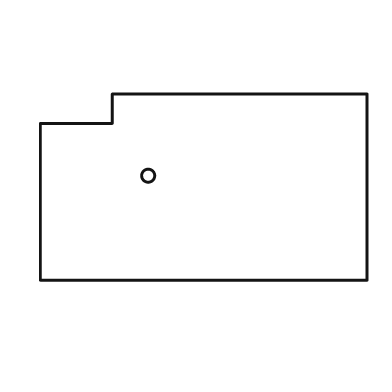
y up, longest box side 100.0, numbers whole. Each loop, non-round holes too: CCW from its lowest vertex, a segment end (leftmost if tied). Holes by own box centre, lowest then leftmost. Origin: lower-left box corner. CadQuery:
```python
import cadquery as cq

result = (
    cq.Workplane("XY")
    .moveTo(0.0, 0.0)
    .lineTo(100.0, 0.0)
    .lineTo(100.0, 57.0)
    .lineTo(22.0, 57.0)
    .lineTo(22.0, 48.0)
    .lineTo(0.0, 48.0)
    .close()
    .moveTo(33.0, 32.0)
    .circle(2.0)
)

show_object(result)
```